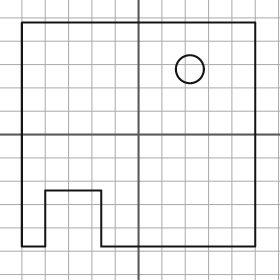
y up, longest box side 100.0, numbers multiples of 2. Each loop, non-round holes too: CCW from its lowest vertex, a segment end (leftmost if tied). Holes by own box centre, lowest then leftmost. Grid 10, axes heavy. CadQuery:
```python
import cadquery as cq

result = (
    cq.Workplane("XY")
    .moveTo(-50.0, -48.0)
    .lineTo(-40.0, -48.0)
    .lineTo(-40.0, -24.0)
    .lineTo(-16.0, -24.0)
    .lineTo(-16.0, -48.0)
    .lineTo(50.0, -48.0)
    .lineTo(50.0, 48.0)
    .lineTo(-50.0, 48.0)
    .close()
    .moveTo(22.0, 28.0)
    .circle(6.0)
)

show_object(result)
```